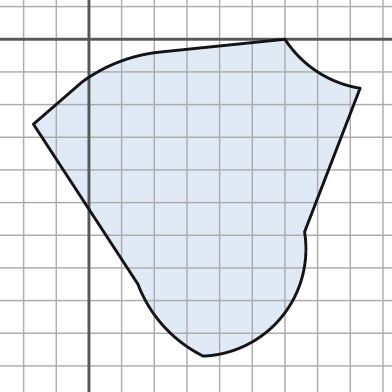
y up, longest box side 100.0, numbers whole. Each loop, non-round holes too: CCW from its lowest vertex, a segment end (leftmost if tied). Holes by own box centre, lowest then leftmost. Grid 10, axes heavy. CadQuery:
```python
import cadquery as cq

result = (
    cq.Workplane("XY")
    .moveTo(35.0, -97.0)
    .threePointArc((59.0, -85.0), (66.0, -59.0))
    .lineTo(83.0, -15.0)
    .threePointArc((70.0, -10.0), (60.0, 0.0))
    .lineTo(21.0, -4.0)
    .threePointArc((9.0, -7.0), (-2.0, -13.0))
    .lineTo(-17.0, -26.0)
    .lineTo(15.0, -75.0)
    .threePointArc((23.0, -88.0), (35.0, -97.0))
    .close()
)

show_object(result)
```